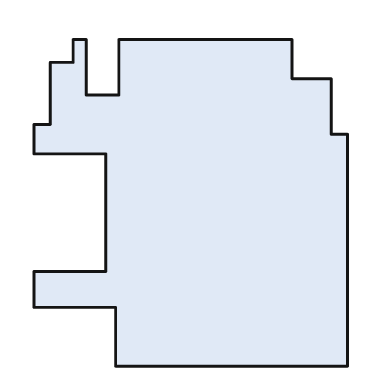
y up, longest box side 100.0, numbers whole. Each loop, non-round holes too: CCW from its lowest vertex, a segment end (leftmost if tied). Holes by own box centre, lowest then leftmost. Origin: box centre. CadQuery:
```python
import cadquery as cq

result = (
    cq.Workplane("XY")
    .moveTo(-23.0, -50.0)
    .lineTo(48.0, -50.0)
    .lineTo(48.0, 21.0)
    .lineTo(43.0, 21.0)
    .lineTo(43.0, 38.0)
    .lineTo(31.0, 38.0)
    .lineTo(31.0, 50.0)
    .lineTo(-22.0, 50.0)
    .lineTo(-22.0, 33.0)
    .lineTo(-32.0, 33.0)
    .lineTo(-32.0, 50.0)
    .lineTo(-36.0, 50.0)
    .lineTo(-36.0, 43.0)
    .lineTo(-43.0, 43.0)
    .lineTo(-43.0, 24.0)
    .lineTo(-48.0, 24.0)
    .lineTo(-48.0, 15.0)
    .lineTo(-26.0, 15.0)
    .lineTo(-26.0, -21.0)
    .lineTo(-48.0, -21.0)
    .lineTo(-48.0, -32.0)
    .lineTo(-23.0, -32.0)
    .close()
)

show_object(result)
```